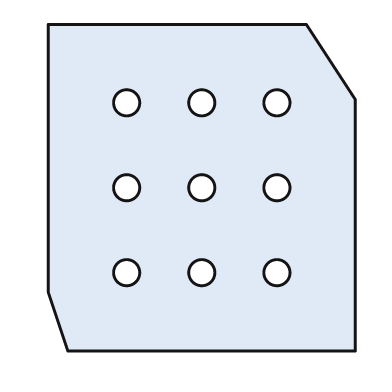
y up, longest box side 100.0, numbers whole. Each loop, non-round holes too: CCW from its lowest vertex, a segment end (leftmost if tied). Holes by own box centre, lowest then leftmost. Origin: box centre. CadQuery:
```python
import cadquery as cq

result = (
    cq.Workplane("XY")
    .moveTo(-41.0, -50.0)
    .lineTo(47.0, -50.0)
    .lineTo(47.0, 27.0)
    .lineTo(32.0, 50.0)
    .lineTo(-47.0, 50.0)
    .lineTo(-47.0, -32.0)
    .close()
    .moveTo(-23.0, -26.0)
    .circle(4.0)
    .moveTo(0.0, -26.0)
    .circle(4.0)
    .moveTo(23.0, -26.0)
    .circle(4.0)
    .moveTo(-23.0, 0.0)
    .circle(4.0)
    .moveTo(0.0, 0.0)
    .circle(4.0)
    .moveTo(23.0, 0.0)
    .circle(4.0)
    .moveTo(-23.0, 26.0)
    .circle(4.0)
    .moveTo(0.0, 26.0)
    .circle(4.0)
    .moveTo(23.0, 26.0)
    .circle(4.0)
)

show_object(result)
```